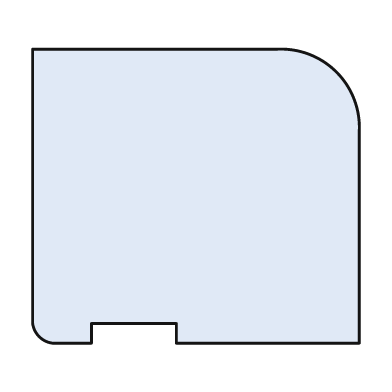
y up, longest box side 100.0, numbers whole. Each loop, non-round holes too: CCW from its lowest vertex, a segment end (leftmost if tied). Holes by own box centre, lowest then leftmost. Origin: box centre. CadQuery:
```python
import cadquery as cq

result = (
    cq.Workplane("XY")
    .moveTo(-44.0, -45.0)
    .lineTo(-32.0, -45.0)
    .lineTo(-32.0, -39.0)
    .lineTo(-6.0, -39.0)
    .lineTo(-6.0, -45.0)
    .lineTo(50.0, -45.0)
    .lineTo(50.0, 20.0)
    .threePointArc((43.0, 38.0), (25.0, 45.0))
    .lineTo(-50.0, 45.0)
    .lineTo(-50.0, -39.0)
    .threePointArc((-48.0, -43.0), (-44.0, -45.0))
    .close()
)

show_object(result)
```